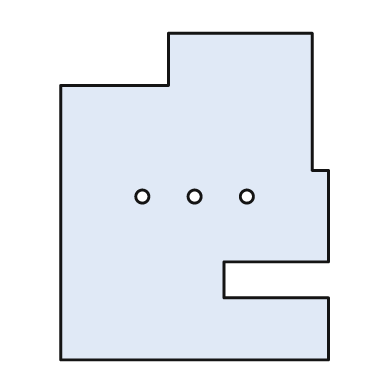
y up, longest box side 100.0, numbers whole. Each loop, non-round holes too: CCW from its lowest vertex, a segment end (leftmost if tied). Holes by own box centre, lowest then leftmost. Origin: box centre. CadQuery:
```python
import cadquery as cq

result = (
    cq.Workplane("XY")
    .moveTo(-41.0, -50.0)
    .lineTo(41.0, -50.0)
    .lineTo(41.0, -31.0)
    .lineTo(9.0, -31.0)
    .lineTo(9.0, -20.0)
    .lineTo(41.0, -20.0)
    .lineTo(41.0, 8.0)
    .lineTo(36.0, 8.0)
    .lineTo(36.0, 50.0)
    .lineTo(-8.0, 50.0)
    .lineTo(-8.0, 34.0)
    .lineTo(-41.0, 34.0)
    .close()
    .moveTo(-16.0, 0.0)
    .circle(2.0)
    .moveTo(0.0, 0.0)
    .circle(2.0)
    .moveTo(16.0, 0.0)
    .circle(2.0)
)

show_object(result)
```